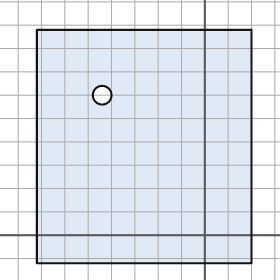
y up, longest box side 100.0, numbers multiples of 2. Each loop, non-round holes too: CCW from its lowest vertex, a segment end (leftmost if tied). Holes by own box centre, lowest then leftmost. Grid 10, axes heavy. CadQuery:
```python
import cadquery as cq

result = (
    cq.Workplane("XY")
    .moveTo(-72.0, -12.0)
    .lineTo(20.0, -12.0)
    .lineTo(20.0, 88.0)
    .lineTo(-72.0, 88.0)
    .close()
    .moveTo(-44.0, 60.0)
    .circle(4.0)
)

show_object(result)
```